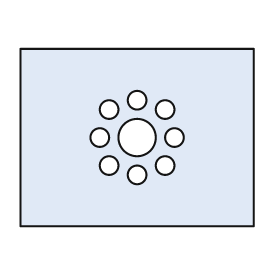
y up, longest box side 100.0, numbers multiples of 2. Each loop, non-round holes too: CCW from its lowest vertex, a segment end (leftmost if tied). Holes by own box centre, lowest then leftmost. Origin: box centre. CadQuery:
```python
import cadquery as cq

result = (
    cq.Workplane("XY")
    .moveTo(-50.0, -38.0)
    .lineTo(50.0, -38.0)
    .lineTo(50.0, 38.0)
    .lineTo(-50.0, 38.0)
    .close()
    .moveTo(0.0, -16.0)
    .circle(4.0)
    .moveTo(-12.0, -12.0)
    .circle(4.0)
    .moveTo(12.0, -12.0)
    .circle(4.0)
    .moveTo(-16.0, 0.0)
    .circle(4.0)
    .moveTo(0.0, 0.0)
    .circle(8.0)
    .moveTo(16.0, 0.0)
    .circle(4.0)
    .moveTo(-12.0, 12.0)
    .circle(4.0)
    .moveTo(12.0, 12.0)
    .circle(4.0)
    .moveTo(0.0, 16.0)
    .circle(4.0)
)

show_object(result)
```